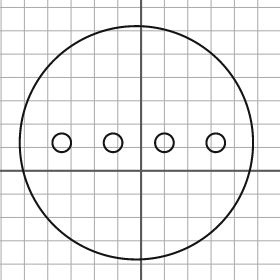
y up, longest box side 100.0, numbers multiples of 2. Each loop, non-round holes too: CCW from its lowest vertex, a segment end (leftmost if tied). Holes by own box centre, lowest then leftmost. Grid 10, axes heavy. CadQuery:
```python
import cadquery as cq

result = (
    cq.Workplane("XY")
    .moveTo(-2.0, 12.0)
    .circle(50.0)
    .moveTo(-34.0, 12.0)
    .circle(4.0)
    .moveTo(-12.0, 12.0)
    .circle(4.0)
    .moveTo(10.0, 12.0)
    .circle(4.0)
    .moveTo(32.0, 12.0)
    .circle(4.0)
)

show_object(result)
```